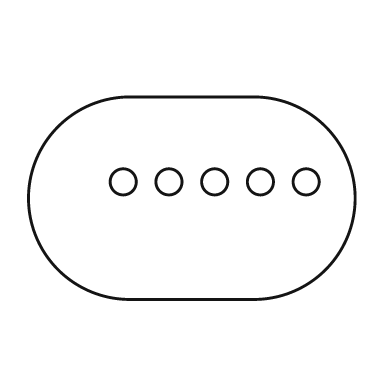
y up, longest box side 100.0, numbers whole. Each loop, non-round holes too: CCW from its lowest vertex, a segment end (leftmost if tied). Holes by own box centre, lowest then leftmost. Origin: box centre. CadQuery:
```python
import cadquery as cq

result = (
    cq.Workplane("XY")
    .moveTo(-19.0, -31.0)
    .lineTo(19.0, -31.0)
    .threePointArc((50.0, 0.0), (19.0, 31.0))
    .lineTo(-19.0, 31.0)
    .threePointArc((-50.0, 0.0), (-19.0, -31.0))
    .close()
    .moveTo(-21.0, 5.0)
    .circle(4.0)
    .moveTo(-7.0, 5.0)
    .circle(4.0)
    .moveTo(7.0, 5.0)
    .circle(4.0)
    .moveTo(21.0, 5.0)
    .circle(4.0)
    .moveTo(35.0, 5.0)
    .circle(4.0)
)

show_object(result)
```